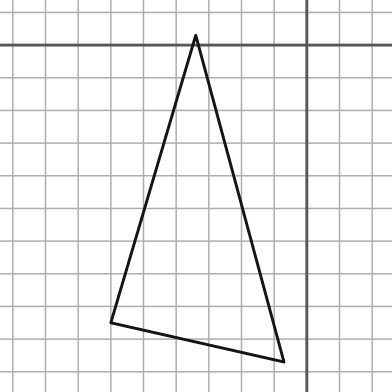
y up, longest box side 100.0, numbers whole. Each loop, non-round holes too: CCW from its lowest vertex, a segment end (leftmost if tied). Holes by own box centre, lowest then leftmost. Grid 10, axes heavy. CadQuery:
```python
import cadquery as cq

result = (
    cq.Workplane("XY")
    .moveTo(-7.0, -97.0)
    .lineTo(-34.0, 3.0)
    .lineTo(-60.0, -85.0)
    .close()
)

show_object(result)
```